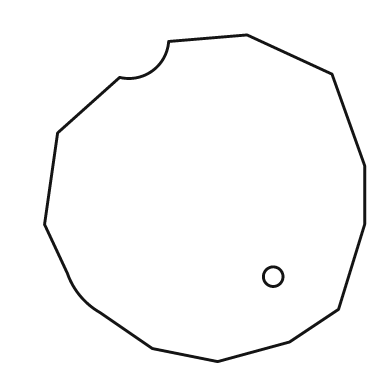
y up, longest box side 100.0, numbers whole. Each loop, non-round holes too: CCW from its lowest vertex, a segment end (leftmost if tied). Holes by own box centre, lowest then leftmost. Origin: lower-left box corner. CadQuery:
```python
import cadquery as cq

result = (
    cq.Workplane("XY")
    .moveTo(53.0, 0.0)
    .lineTo(75.0, 6.0)
    .lineTo(90.0, 16.0)
    .lineTo(98.0, 42.0)
    .lineTo(98.0, 60.0)
    .lineTo(88.0, 88.0)
    .lineTo(62.0, 100.0)
    .lineTo(38.0, 98.0)
    .threePointArc((33.0, 89.0), (23.0, 87.0))
    .lineTo(4.0, 70.0)
    .lineTo(0.0, 42.0)
    .lineTo(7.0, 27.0)
    .threePointArc((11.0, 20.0), (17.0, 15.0))
    .lineTo(33.0, 4.0)
    .close()
    .moveTo(70.0, 26.0)
    .circle(3.0)
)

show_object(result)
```